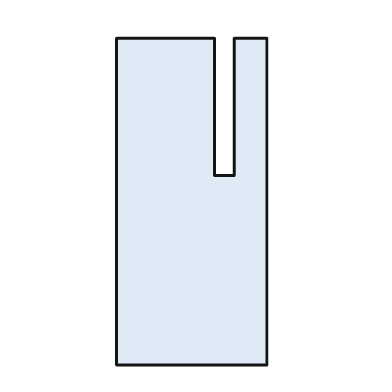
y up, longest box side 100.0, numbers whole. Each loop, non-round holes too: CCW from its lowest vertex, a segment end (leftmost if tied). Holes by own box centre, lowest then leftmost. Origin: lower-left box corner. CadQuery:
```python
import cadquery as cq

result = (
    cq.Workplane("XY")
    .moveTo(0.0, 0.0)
    .lineTo(46.0, 0.0)
    .lineTo(46.0, 100.0)
    .lineTo(36.0, 100.0)
    .lineTo(36.0, 58.0)
    .lineTo(30.0, 58.0)
    .lineTo(30.0, 100.0)
    .lineTo(0.0, 100.0)
    .close()
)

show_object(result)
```